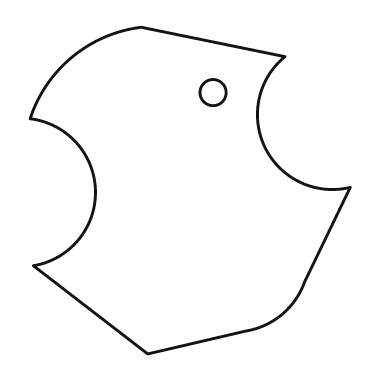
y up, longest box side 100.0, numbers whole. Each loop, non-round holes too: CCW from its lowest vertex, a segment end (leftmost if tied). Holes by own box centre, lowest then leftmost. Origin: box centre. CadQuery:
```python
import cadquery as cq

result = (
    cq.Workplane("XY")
    .moveTo(-13.0, -50.0)
    .lineTo(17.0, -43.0)
    .threePointArc((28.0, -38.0), (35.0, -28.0))
    .lineTo(49.0, 1.0)
    .threePointArc((23.0, 13.0), (29.0, 41.0))
    .lineTo(-15.0, 50.0)
    .threePointArc((-36.0, 41.0), (-49.0, 22.0))
    .threePointArc((-29.0, 0.0), (-48.0, -23.0))
    .close()
    .moveTo(7.0, 30.0)
    .circle(4.0)
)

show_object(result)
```